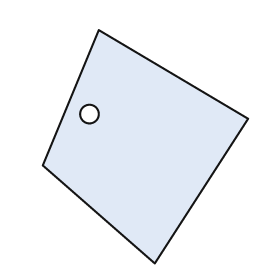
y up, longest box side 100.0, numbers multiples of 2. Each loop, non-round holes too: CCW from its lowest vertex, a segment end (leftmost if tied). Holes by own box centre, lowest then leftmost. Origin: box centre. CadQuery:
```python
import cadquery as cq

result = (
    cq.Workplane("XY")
    .moveTo(4.0, -50.0)
    .lineTo(44.0, 12.0)
    .lineTo(-20.0, 50.0)
    .lineTo(-44.0, -8.0)
    .close()
    .moveTo(-24.0, 14.0)
    .circle(4.0)
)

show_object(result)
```